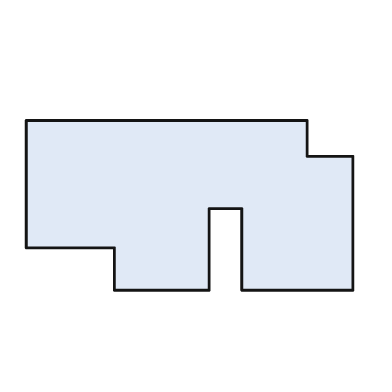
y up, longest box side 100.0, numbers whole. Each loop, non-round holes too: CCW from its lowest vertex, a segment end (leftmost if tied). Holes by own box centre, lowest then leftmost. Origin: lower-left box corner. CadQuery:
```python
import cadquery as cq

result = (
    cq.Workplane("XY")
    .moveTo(27.0, 0.0)
    .lineTo(56.0, 0.0)
    .lineTo(56.0, 25.0)
    .lineTo(66.0, 25.0)
    .lineTo(66.0, 0.0)
    .lineTo(100.0, 0.0)
    .lineTo(100.0, 41.0)
    .lineTo(86.0, 41.0)
    .lineTo(86.0, 52.0)
    .lineTo(0.0, 52.0)
    .lineTo(0.0, 13.0)
    .lineTo(27.0, 13.0)
    .close()
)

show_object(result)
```